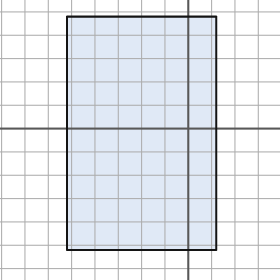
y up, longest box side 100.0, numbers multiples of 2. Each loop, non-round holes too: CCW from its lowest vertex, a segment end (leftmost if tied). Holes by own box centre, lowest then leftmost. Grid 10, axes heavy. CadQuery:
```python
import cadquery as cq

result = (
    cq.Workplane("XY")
    .moveTo(-52.0, -52.0)
    .lineTo(12.0, -52.0)
    .lineTo(12.0, 48.0)
    .lineTo(-52.0, 48.0)
    .close()
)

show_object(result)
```